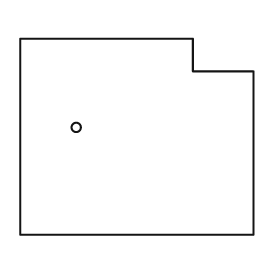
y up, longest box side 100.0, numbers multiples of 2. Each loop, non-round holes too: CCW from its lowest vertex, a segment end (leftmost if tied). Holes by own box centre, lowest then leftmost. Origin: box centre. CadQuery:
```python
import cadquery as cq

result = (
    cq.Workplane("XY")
    .moveTo(-50.0, -42.0)
    .lineTo(50.0, -42.0)
    .lineTo(50.0, 28.0)
    .lineTo(24.0, 28.0)
    .lineTo(24.0, 42.0)
    .lineTo(-50.0, 42.0)
    .close()
    .moveTo(-26.0, 4.0)
    .circle(2.0)
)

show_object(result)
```